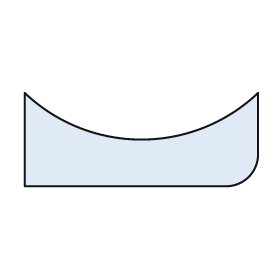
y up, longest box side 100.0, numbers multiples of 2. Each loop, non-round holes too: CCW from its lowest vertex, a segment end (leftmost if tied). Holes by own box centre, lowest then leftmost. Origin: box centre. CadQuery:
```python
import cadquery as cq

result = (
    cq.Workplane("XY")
    .moveTo(-50.0, -20.0)
    .lineTo(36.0, -20.0)
    .threePointArc((46.0, -16.0), (50.0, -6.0))
    .lineTo(50.0, 20.0)
    .threePointArc((0.0, 0.0), (-50.0, 20.0))
    .close()
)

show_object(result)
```